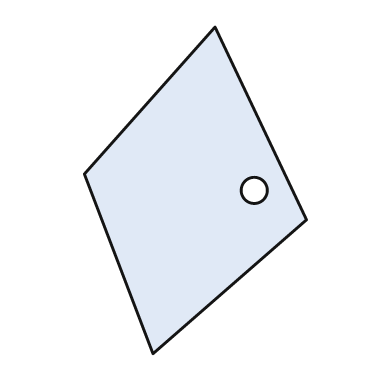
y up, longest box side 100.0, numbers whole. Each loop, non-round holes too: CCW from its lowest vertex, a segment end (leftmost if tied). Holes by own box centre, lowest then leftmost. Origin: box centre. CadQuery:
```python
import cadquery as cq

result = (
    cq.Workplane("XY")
    .moveTo(-13.0, -50.0)
    .lineTo(34.0, -9.0)
    .lineTo(6.0, 50.0)
    .lineTo(-34.0, 5.0)
    .close()
    .moveTo(18.0, 0.0)
    .circle(4.0)
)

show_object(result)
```